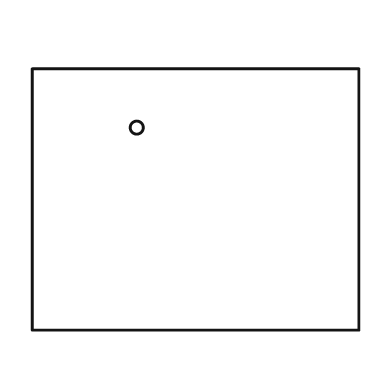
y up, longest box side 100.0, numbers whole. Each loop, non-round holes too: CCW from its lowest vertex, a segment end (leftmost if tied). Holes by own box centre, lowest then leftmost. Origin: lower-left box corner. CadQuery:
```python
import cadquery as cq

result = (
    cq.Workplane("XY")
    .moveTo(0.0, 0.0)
    .lineTo(100.0, 0.0)
    .lineTo(100.0, 80.0)
    .lineTo(0.0, 80.0)
    .close()
    .moveTo(32.0, 62.0)
    .circle(2.0)
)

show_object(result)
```